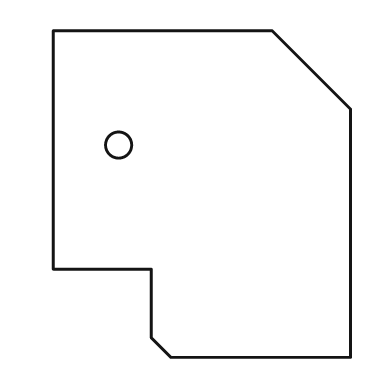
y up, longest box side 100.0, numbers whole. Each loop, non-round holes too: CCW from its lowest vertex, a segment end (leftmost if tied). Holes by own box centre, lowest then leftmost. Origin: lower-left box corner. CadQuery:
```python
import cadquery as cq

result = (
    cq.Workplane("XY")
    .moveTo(36.0, 0.0)
    .lineTo(91.0, 0.0)
    .lineTo(91.0, 76.0)
    .lineTo(67.0, 100.0)
    .lineTo(0.0, 100.0)
    .lineTo(0.0, 27.0)
    .lineTo(30.0, 27.0)
    .lineTo(30.0, 6.0)
    .close()
    .moveTo(20.0, 65.0)
    .circle(4.0)
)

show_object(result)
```